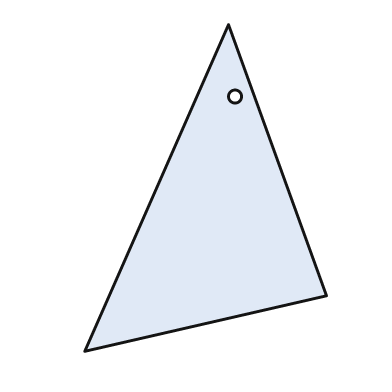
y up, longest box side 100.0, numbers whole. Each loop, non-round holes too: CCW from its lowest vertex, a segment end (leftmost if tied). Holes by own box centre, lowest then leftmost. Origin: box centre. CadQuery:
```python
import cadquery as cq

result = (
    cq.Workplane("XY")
    .moveTo(-37.0, -50.0)
    .lineTo(37.0, -33.0)
    .lineTo(7.0, 50.0)
    .close()
    .moveTo(9.0, 28.0)
    .circle(2.0)
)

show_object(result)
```